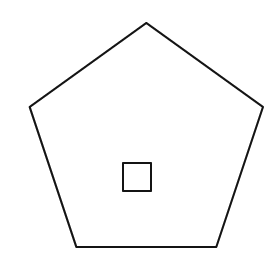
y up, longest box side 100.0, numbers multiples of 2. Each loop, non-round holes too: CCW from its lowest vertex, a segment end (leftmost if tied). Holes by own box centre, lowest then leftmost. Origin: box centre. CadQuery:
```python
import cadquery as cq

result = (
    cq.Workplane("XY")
    .moveTo(-30.0, -48.0)
    .lineTo(30.0, -48.0)
    .lineTo(50.0, 12.0)
    .lineTo(0.0, 48.0)
    .lineTo(-50.0, 12.0)
    .close()
    .moveTo(-10.0, -24.0)
    .lineTo(2.0, -24.0)
    .lineTo(2.0, -12.0)
    .lineTo(-10.0, -12.0)
    .close()
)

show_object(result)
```